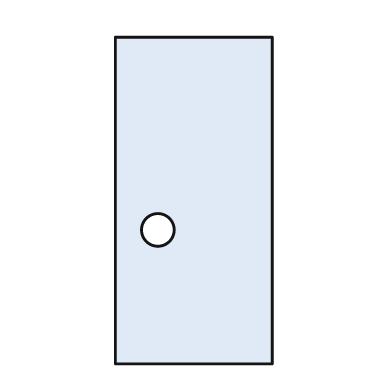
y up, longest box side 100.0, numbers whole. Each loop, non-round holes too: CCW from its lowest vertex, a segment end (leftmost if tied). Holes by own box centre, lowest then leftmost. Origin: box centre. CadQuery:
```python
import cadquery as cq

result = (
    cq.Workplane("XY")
    .moveTo(-24.0, -50.0)
    .lineTo(24.0, -50.0)
    .lineTo(24.0, 50.0)
    .lineTo(-24.0, 50.0)
    .close()
    .moveTo(-11.0, -9.0)
    .circle(5.0)
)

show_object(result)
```